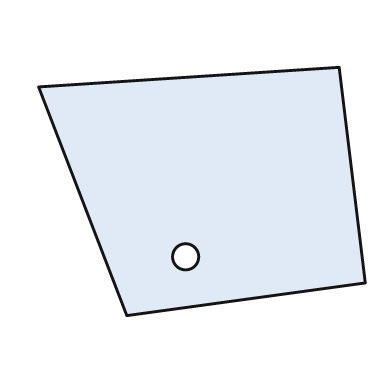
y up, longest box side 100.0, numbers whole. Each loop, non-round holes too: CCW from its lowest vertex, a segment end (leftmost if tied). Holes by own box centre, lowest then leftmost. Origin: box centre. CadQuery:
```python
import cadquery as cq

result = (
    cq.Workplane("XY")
    .moveTo(-23.0, -38.0)
    .lineTo(50.0, -28.0)
    .lineTo(42.0, 38.0)
    .lineTo(-50.0, 32.0)
    .close()
    .moveTo(-5.0, -20.0)
    .circle(4.0)
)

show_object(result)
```